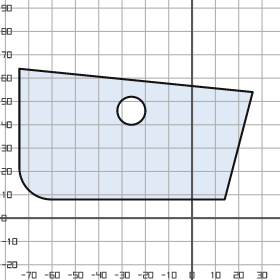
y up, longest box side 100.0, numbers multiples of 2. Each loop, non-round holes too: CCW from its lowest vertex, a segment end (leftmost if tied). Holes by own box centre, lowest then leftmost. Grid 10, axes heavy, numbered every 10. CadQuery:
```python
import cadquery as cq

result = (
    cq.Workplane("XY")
    .moveTo(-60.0, 8.0)
    .lineTo(14.0, 8.0)
    .lineTo(26.0, 54.0)
    .lineTo(-74.0, 64.0)
    .lineTo(-74.0, 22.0)
    .threePointArc((-70.0, 12.0), (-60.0, 8.0))
    .close()
    .moveTo(-26.0, 46.0)
    .circle(6.0)
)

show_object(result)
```